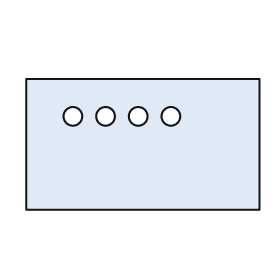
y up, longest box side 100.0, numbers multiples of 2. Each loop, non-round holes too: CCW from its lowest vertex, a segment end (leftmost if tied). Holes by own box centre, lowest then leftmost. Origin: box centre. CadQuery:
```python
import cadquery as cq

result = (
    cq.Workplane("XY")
    .moveTo(-50.0, -28.0)
    .lineTo(50.0, -28.0)
    .lineTo(50.0, 28.0)
    .lineTo(-50.0, 28.0)
    .close()
    .moveTo(-30.0, 12.0)
    .circle(4.0)
    .moveTo(-16.0, 12.0)
    .circle(4.0)
    .moveTo(-2.0, 12.0)
    .circle(4.0)
    .moveTo(12.0, 12.0)
    .circle(4.0)
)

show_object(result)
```